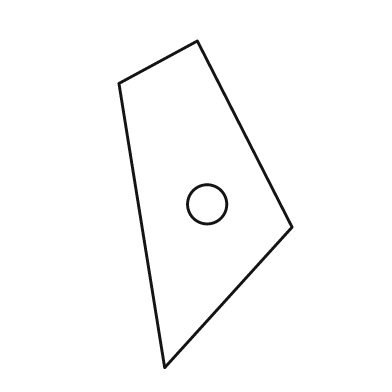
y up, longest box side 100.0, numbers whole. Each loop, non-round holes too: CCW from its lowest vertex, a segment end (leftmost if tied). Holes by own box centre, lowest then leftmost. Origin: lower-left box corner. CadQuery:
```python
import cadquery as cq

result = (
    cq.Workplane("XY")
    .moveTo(14.0, 0.0)
    .lineTo(53.0, 43.0)
    .lineTo(24.0, 100.0)
    .lineTo(0.0, 87.0)
    .close()
    .moveTo(27.0, 50.0)
    .circle(6.0)
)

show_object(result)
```